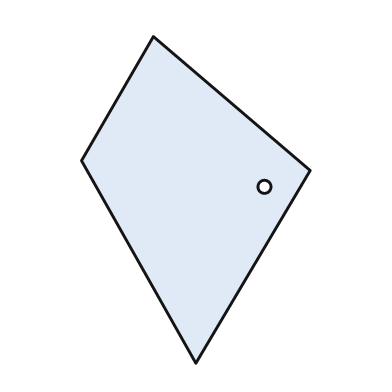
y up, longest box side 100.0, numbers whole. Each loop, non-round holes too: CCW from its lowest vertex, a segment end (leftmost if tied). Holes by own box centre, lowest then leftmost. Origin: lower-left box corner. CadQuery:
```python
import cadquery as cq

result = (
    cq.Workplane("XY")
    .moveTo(35.0, 0.0)
    .lineTo(70.0, 59.0)
    .lineTo(22.0, 100.0)
    .lineTo(0.0, 62.0)
    .close()
    .moveTo(56.0, 54.0)
    .circle(2.0)
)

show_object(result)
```